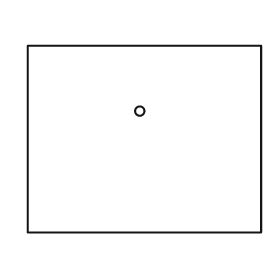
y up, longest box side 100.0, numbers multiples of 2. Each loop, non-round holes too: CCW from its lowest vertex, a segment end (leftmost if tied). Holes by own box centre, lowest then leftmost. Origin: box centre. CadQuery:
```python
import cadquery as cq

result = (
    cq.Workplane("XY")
    .moveTo(-50.0, -40.0)
    .lineTo(50.0, -40.0)
    .lineTo(50.0, 40.0)
    .lineTo(-50.0, 40.0)
    .close()
    .moveTo(-2.0, 12.0)
    .circle(2.0)
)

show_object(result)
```